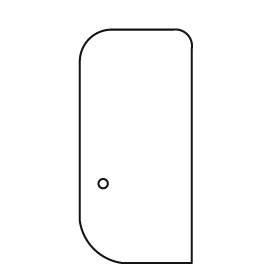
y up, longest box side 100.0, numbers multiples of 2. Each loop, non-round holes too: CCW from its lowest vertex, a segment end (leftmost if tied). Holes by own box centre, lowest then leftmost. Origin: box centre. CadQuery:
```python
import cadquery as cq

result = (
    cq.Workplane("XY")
    .moveTo(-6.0, -50.0)
    .lineTo(24.0, -50.0)
    .lineTo(24.0, 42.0)
    .threePointArc((22.0, 48.0), (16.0, 50.0))
    .lineTo(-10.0, 50.0)
    .threePointArc((-20.0, 46.0), (-24.0, 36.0))
    .lineTo(-24.0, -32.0)
    .threePointArc((-18.0, -44.0), (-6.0, -50.0))
    .close()
    .moveTo(-14.0, -16.0)
    .circle(2.0)
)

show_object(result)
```